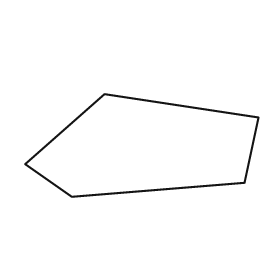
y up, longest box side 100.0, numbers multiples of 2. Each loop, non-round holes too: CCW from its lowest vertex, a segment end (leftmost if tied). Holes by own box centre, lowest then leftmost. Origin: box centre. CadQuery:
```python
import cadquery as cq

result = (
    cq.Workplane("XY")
    .moveTo(-30.0, -22.0)
    .lineTo(44.0, -16.0)
    .lineTo(50.0, 12.0)
    .lineTo(-16.0, 22.0)
    .lineTo(-50.0, -8.0)
    .close()
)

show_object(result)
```